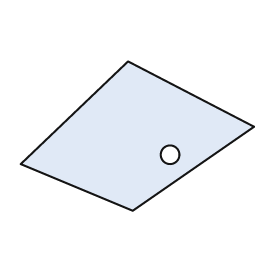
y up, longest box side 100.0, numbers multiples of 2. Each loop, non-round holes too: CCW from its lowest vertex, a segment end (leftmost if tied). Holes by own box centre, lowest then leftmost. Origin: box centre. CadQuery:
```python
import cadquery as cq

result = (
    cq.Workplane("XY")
    .moveTo(-2.0, -32.0)
    .lineTo(50.0, 4.0)
    .lineTo(-4.0, 32.0)
    .lineTo(-50.0, -12.0)
    .close()
    .moveTo(14.0, -8.0)
    .circle(4.0)
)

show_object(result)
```